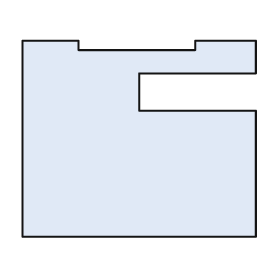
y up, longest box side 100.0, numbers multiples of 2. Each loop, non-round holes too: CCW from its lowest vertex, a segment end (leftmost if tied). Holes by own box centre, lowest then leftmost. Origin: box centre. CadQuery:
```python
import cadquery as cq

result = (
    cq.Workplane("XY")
    .moveTo(-50.0, -42.0)
    .lineTo(50.0, -42.0)
    .lineTo(50.0, 12.0)
    .lineTo(0.0, 12.0)
    .lineTo(0.0, 28.0)
    .lineTo(50.0, 28.0)
    .lineTo(50.0, 42.0)
    .lineTo(24.0, 42.0)
    .lineTo(24.0, 38.0)
    .lineTo(-26.0, 38.0)
    .lineTo(-26.0, 42.0)
    .lineTo(-50.0, 42.0)
    .close()
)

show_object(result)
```